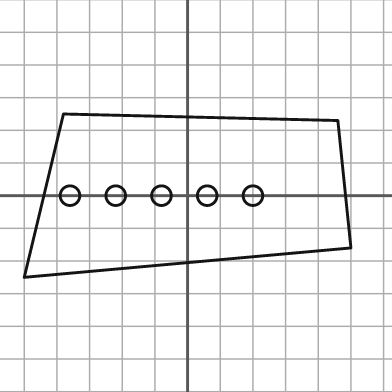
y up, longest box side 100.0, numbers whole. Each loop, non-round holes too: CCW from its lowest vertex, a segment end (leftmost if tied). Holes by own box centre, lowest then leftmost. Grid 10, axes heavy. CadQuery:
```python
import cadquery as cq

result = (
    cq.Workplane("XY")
    .moveTo(-50.0, -25.0)
    .lineTo(50.0, -16.0)
    .lineTo(46.0, 23.0)
    .lineTo(-38.0, 25.0)
    .close()
    .moveTo(-36.0, 0.0)
    .circle(3.0)
    .moveTo(-22.0, 0.0)
    .circle(3.0)
    .moveTo(-8.0, 0.0)
    .circle(3.0)
    .moveTo(6.0, 0.0)
    .circle(3.0)
    .moveTo(20.0, 0.0)
    .circle(3.0)
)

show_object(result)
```